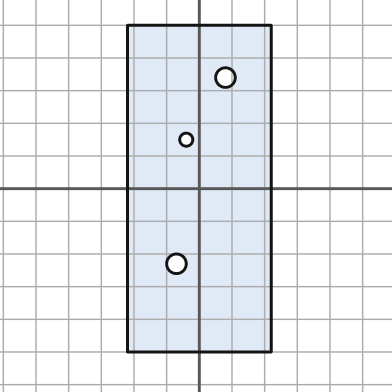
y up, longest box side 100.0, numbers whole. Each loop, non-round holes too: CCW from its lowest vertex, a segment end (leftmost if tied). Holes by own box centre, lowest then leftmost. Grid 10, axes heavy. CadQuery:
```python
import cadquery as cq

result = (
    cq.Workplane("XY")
    .moveTo(-22.0, -50.0)
    .lineTo(22.0, -50.0)
    .lineTo(22.0, 50.0)
    .lineTo(-22.0, 50.0)
    .close()
    .moveTo(-7.0, -23.0)
    .circle(3.0)
    .moveTo(-4.0, 15.0)
    .circle(2.0)
    .moveTo(8.0, 34.0)
    .circle(3.0)
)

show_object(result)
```